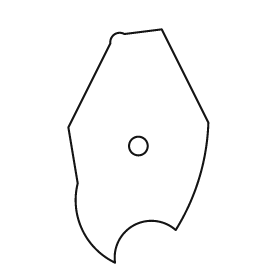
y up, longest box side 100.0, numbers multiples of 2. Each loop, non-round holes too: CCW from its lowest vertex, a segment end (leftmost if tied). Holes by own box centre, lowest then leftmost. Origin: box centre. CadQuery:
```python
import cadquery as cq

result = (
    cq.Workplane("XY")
    .moveTo(-10.0, -50.0)
    .threePointArc((-2.0, -34.0), (16.0, -36.0))
    .threePointArc((26.0, -14.0), (30.0, 10.0))
    .lineTo(10.0, 50.0)
    .lineTo(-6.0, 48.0)
    .threePointArc((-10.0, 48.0), (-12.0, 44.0))
    .lineTo(-30.0, 8.0)
    .lineTo(-26.0, -16.0)
    .threePointArc((-24.0, -36.0), (-10.0, -50.0))
    .close()
    .moveTo(0.0, 0.0)
    .circle(4.0)
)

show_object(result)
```